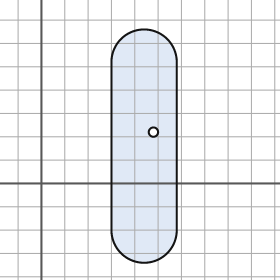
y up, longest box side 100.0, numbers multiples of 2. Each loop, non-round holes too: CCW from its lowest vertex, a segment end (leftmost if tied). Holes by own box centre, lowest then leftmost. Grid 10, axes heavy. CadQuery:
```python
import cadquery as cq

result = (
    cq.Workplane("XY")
    .moveTo(30.0, -20.0)
    .threePointArc((44.0, -34.0), (58.0, -20.0))
    .lineTo(58.0, 52.0)
    .threePointArc((44.0, 66.0), (30.0, 52.0))
    .close()
    .moveTo(48.0, 22.0)
    .circle(2.0)
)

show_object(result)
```